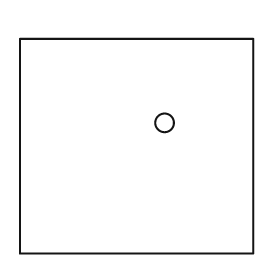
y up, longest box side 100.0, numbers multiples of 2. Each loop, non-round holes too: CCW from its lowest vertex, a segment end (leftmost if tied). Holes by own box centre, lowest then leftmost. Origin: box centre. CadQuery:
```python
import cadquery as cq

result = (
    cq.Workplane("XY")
    .moveTo(-50.0, -46.0)
    .lineTo(50.0, -46.0)
    .lineTo(50.0, 46.0)
    .lineTo(-50.0, 46.0)
    .close()
    .moveTo(12.0, 10.0)
    .circle(4.0)
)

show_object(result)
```